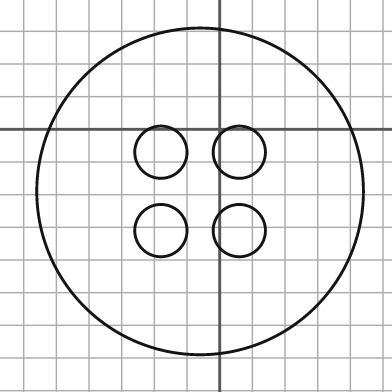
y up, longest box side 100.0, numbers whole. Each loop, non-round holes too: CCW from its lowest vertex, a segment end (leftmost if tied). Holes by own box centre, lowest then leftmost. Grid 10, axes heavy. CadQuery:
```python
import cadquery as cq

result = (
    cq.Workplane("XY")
    .moveTo(-6.0, -19.0)
    .circle(50.0)
    .moveTo(-18.0, -31.0)
    .circle(8.0)
    .moveTo(6.0, -31.0)
    .circle(8.0)
    .moveTo(-18.0, -7.0)
    .circle(8.0)
    .moveTo(6.0, -7.0)
    .circle(8.0)
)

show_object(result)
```